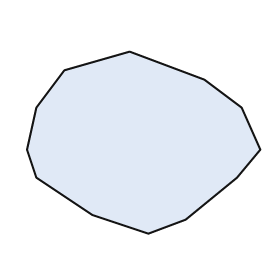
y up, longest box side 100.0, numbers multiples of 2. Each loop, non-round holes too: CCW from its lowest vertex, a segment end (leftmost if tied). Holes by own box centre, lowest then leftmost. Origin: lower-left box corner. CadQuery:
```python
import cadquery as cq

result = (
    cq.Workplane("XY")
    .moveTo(52.0, 0.0)
    .lineTo(68.0, 6.0)
    .lineTo(90.0, 24.0)
    .lineTo(100.0, 36.0)
    .lineTo(92.0, 54.0)
    .lineTo(76.0, 66.0)
    .lineTo(44.0, 78.0)
    .lineTo(16.0, 70.0)
    .lineTo(4.0, 54.0)
    .lineTo(0.0, 36.0)
    .lineTo(4.0, 24.0)
    .lineTo(28.0, 8.0)
    .close()
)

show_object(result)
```